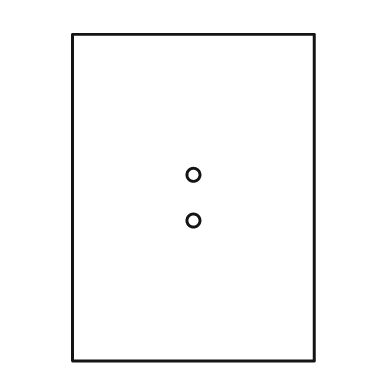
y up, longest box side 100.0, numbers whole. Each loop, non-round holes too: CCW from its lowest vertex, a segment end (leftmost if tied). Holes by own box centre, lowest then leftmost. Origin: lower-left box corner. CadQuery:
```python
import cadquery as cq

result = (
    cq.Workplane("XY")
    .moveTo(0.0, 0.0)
    .lineTo(74.0, 0.0)
    .lineTo(74.0, 100.0)
    .lineTo(0.0, 100.0)
    .close()
    .moveTo(37.0, 43.0)
    .circle(2.0)
    .moveTo(37.0, 57.0)
    .circle(2.0)
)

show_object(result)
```